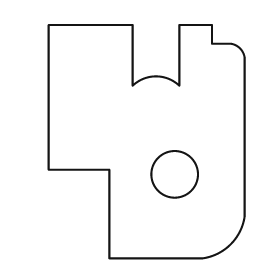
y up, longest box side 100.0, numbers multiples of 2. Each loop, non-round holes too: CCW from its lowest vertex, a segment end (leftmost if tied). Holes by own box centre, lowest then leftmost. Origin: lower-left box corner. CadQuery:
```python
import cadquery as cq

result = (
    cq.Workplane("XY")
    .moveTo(26.0, 0.0)
    .lineTo(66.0, 0.0)
    .threePointArc((78.0, 6.0), (84.0, 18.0))
    .lineTo(84.0, 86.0)
    .threePointArc((82.0, 90.0), (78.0, 92.0))
    .lineTo(70.0, 92.0)
    .lineTo(70.0, 100.0)
    .lineTo(56.0, 100.0)
    .lineTo(56.0, 74.0)
    .threePointArc((46.0, 78.0), (36.0, 74.0))
    .lineTo(36.0, 100.0)
    .lineTo(0.0, 100.0)
    .lineTo(0.0, 38.0)
    .lineTo(26.0, 38.0)
    .close()
    .moveTo(54.0, 36.0)
    .circle(10.0)
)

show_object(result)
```